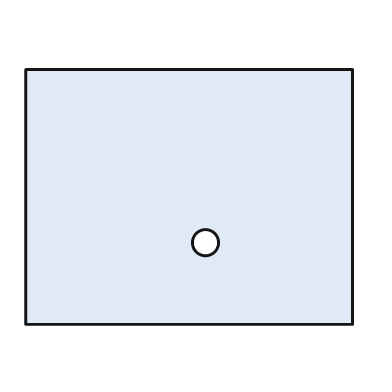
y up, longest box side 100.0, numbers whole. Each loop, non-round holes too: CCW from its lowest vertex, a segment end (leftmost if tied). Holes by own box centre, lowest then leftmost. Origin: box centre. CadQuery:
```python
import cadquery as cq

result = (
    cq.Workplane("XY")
    .moveTo(-50.0, -39.0)
    .lineTo(50.0, -39.0)
    .lineTo(50.0, 39.0)
    .lineTo(-50.0, 39.0)
    .close()
    .moveTo(5.0, -14.0)
    .circle(4.0)
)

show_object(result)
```